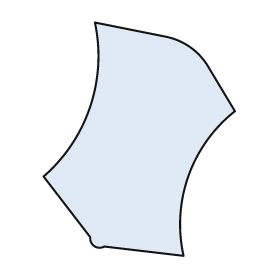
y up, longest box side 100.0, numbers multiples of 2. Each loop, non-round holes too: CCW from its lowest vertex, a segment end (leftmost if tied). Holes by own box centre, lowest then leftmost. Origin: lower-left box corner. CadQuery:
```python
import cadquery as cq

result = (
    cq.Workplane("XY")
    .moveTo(60.0, 0.0)
    .threePointArc((62.0, 34.0), (82.0, 62.0))
    .lineTo(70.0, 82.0)
    .threePointArc((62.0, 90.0), (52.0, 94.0))
    .lineTo(22.0, 100.0)
    .threePointArc((20.0, 64.0), (0.0, 34.0))
    .lineTo(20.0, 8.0)
    .threePointArc((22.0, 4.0), (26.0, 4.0))
    .close()
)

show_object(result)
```